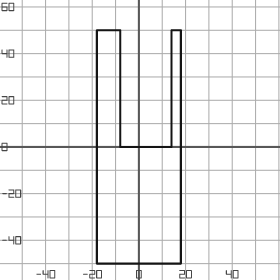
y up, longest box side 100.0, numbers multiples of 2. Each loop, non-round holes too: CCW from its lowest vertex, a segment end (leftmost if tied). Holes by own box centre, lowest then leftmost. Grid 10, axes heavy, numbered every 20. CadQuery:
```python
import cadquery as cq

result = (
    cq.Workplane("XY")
    .moveTo(-18.0, -50.0)
    .lineTo(18.0, -50.0)
    .lineTo(18.0, 50.0)
    .lineTo(14.0, 50.0)
    .lineTo(14.0, 0.0)
    .lineTo(-8.0, 0.0)
    .lineTo(-8.0, 50.0)
    .lineTo(-18.0, 50.0)
    .close()
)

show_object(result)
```